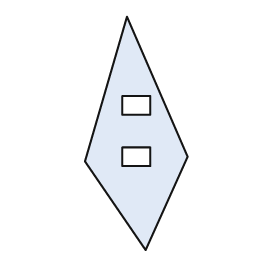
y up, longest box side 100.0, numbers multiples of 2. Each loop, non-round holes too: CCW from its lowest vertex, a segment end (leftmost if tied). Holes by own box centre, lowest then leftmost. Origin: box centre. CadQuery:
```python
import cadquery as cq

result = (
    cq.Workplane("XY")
    .moveTo(4.0, -50.0)
    .lineTo(22.0, -10.0)
    .lineTo(-4.0, 50.0)
    .lineTo(-22.0, -12.0)
    .close()
    .moveTo(-6.0, -14.0)
    .lineTo(6.0, -14.0)
    .lineTo(6.0, -6.0)
    .lineTo(-6.0, -6.0)
    .close()
    .moveTo(-6.0, 8.0)
    .lineTo(6.0, 8.0)
    .lineTo(6.0, 16.0)
    .lineTo(-6.0, 16.0)
    .close()
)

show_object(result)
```